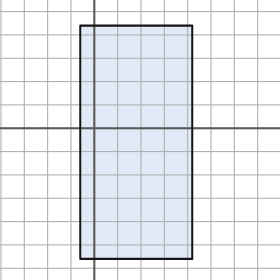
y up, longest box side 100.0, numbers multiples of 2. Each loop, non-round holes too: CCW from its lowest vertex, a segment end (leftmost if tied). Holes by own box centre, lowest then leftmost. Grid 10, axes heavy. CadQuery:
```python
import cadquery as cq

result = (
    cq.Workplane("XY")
    .moveTo(-6.0, -56.0)
    .lineTo(42.0, -56.0)
    .lineTo(42.0, 44.0)
    .lineTo(-6.0, 44.0)
    .close()
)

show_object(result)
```